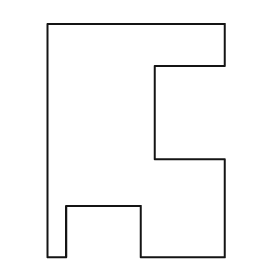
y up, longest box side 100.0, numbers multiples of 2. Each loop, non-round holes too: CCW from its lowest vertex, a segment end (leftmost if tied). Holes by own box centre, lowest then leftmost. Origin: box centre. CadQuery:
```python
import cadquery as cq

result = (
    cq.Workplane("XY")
    .moveTo(-38.0, -50.0)
    .lineTo(-30.0, -50.0)
    .lineTo(-30.0, -28.0)
    .lineTo(2.0, -28.0)
    .lineTo(2.0, -50.0)
    .lineTo(38.0, -50.0)
    .lineTo(38.0, -8.0)
    .lineTo(8.0, -8.0)
    .lineTo(8.0, 32.0)
    .lineTo(38.0, 32.0)
    .lineTo(38.0, 50.0)
    .lineTo(-38.0, 50.0)
    .close()
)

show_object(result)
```